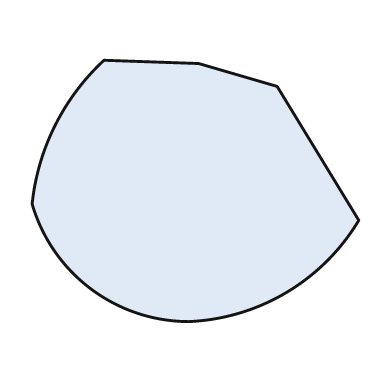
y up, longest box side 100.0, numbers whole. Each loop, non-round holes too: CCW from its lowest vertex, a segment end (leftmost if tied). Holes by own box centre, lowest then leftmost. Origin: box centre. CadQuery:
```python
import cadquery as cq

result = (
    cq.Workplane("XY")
    .moveTo(-2.0, -40.0)
    .threePointArc((28.0, -31.0), (50.0, -9.0))
    .lineTo(25.0, 32.0)
    .lineTo(1.0, 39.0)
    .lineTo(-28.0, 40.0)
    .threePointArc((-43.0, 20.0), (-50.0, -4.0))
    .threePointArc((-32.0, -30.0), (-2.0, -40.0))
    .close()
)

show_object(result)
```